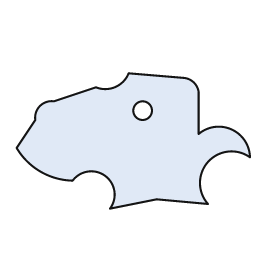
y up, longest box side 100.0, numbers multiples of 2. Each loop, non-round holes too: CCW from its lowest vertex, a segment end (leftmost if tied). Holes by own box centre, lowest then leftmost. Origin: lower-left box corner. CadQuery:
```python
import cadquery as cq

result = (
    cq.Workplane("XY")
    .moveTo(40.0, 0.0)
    .lineTo(60.0, 4.0)
    .lineTo(82.0, 2.0)
    .threePointArc((82.0, 20.0), (100.0, 22.0))
    .threePointArc((92.0, 34.0), (78.0, 32.0))
    .lineTo(78.0, 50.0)
    .threePointArc((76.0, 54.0), (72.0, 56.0))
    .lineTo(48.0, 58.0)
    .threePointArc((42.0, 52.0), (34.0, 52.0))
    .lineTo(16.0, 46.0)
    .threePointArc((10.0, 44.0), (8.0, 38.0))
    .lineTo(0.0, 26.0)
    .threePointArc((10.0, 16.0), (24.0, 12.0))
    .threePointArc((38.0, 14.0), (40.0, 0.0))
    .close()
    .moveTo(54.0, 42.0)
    .circle(4.0)
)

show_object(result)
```